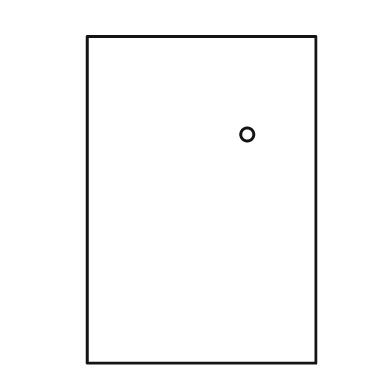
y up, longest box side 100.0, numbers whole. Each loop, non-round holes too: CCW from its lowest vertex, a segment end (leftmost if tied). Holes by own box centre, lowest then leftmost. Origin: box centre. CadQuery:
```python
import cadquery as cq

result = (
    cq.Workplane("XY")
    .moveTo(-35.0, -50.0)
    .lineTo(35.0, -50.0)
    .lineTo(35.0, 50.0)
    .lineTo(-35.0, 50.0)
    .close()
    .moveTo(14.0, 20.0)
    .circle(2.0)
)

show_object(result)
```